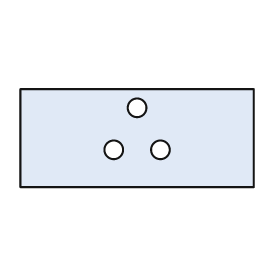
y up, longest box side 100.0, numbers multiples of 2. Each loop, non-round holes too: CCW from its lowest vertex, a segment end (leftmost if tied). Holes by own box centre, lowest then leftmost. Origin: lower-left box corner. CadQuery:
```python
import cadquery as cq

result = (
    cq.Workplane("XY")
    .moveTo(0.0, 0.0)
    .lineTo(100.0, 0.0)
    .lineTo(100.0, 42.0)
    .lineTo(0.0, 42.0)
    .close()
    .moveTo(40.0, 16.0)
    .circle(4.0)
    .moveTo(60.0, 16.0)
    .circle(4.0)
    .moveTo(50.0, 34.0)
    .circle(4.0)
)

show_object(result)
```